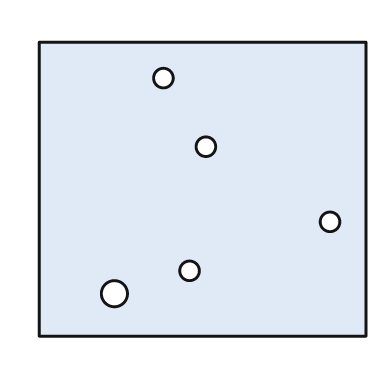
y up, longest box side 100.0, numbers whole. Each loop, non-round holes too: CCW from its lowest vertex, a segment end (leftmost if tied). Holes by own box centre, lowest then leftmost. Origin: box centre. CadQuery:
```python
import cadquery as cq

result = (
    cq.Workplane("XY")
    .moveTo(-50.0, -45.0)
    .lineTo(50.0, -45.0)
    .lineTo(50.0, 45.0)
    .lineTo(-50.0, 45.0)
    .close()
    .moveTo(-27.0, -32.0)
    .circle(4.0)
    .moveTo(-4.0, -25.0)
    .circle(3.0)
    .moveTo(39.0, -10.0)
    .circle(3.0)
    .moveTo(1.0, 13.0)
    .circle(3.0)
    .moveTo(-12.0, 34.0)
    .circle(3.0)
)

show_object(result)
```